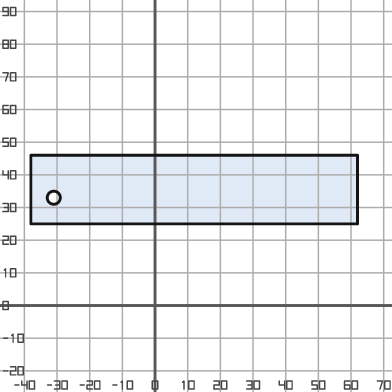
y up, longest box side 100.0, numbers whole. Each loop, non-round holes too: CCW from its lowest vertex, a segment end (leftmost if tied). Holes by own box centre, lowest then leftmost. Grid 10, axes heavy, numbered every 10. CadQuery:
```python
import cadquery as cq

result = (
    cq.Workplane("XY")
    .moveTo(-38.0, 25.0)
    .lineTo(62.0, 25.0)
    .lineTo(62.0, 46.0)
    .lineTo(-38.0, 46.0)
    .close()
    .moveTo(-31.0, 33.0)
    .circle(2.0)
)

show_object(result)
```